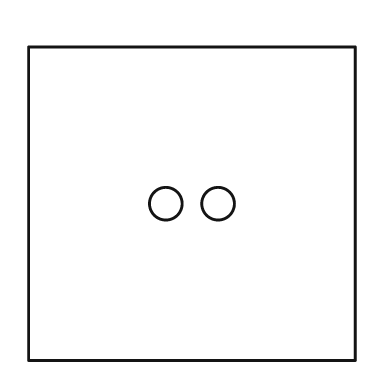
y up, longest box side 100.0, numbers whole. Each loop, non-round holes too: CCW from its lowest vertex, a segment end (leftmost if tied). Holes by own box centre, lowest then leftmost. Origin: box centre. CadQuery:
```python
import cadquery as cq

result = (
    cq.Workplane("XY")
    .moveTo(-50.0, -48.0)
    .lineTo(50.0, -48.0)
    .lineTo(50.0, 48.0)
    .lineTo(-50.0, 48.0)
    .close()
    .moveTo(-8.0, 0.0)
    .circle(5.0)
    .moveTo(8.0, 0.0)
    .circle(5.0)
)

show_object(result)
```